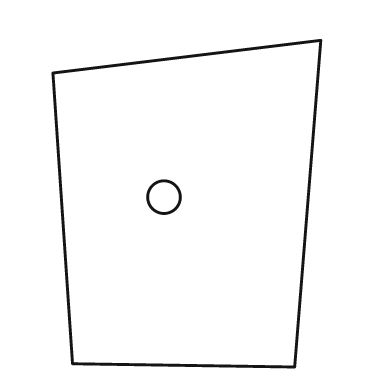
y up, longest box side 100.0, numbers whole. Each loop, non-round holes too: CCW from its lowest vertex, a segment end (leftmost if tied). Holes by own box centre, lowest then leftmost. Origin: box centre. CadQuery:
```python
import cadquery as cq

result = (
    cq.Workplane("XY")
    .moveTo(33.0, -50.0)
    .lineTo(41.0, 50.0)
    .lineTo(-41.0, 40.0)
    .lineTo(-35.0, -49.0)
    .close()
    .moveTo(-7.0, 2.0)
    .circle(5.0)
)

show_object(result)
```